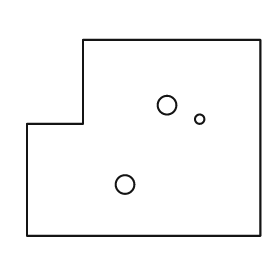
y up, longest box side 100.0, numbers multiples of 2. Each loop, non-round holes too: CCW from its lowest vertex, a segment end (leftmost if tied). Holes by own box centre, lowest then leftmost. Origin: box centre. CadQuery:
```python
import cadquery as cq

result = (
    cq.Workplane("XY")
    .moveTo(-50.0, -42.0)
    .lineTo(50.0, -42.0)
    .lineTo(50.0, 42.0)
    .lineTo(-26.0, 42.0)
    .lineTo(-26.0, 6.0)
    .lineTo(-50.0, 6.0)
    .close()
    .moveTo(-8.0, -20.0)
    .circle(4.0)
    .moveTo(24.0, 8.0)
    .circle(2.0)
    .moveTo(10.0, 14.0)
    .circle(4.0)
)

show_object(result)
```